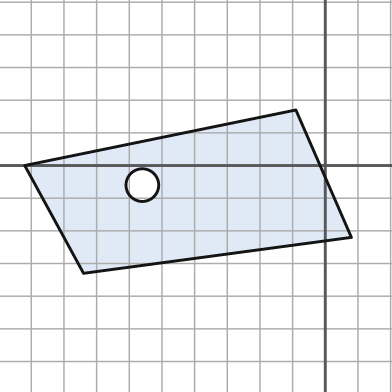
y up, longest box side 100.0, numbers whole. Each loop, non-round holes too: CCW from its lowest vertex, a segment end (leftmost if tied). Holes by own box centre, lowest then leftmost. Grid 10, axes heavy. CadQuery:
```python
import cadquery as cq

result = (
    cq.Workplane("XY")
    .moveTo(-74.0, -33.0)
    .lineTo(8.0, -22.0)
    .lineTo(-9.0, 17.0)
    .lineTo(-92.0, 0.0)
    .close()
    .moveTo(-56.0, -6.0)
    .circle(5.0)
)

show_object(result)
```